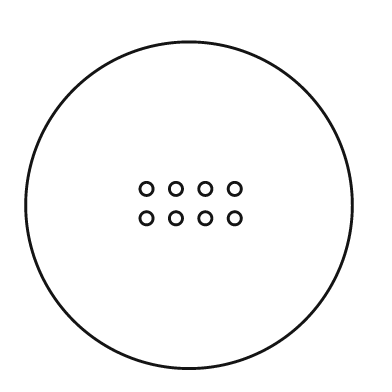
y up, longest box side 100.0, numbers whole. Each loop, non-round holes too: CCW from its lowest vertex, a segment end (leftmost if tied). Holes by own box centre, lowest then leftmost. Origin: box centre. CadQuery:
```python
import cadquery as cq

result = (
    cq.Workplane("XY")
    .moveTo(0.0, 0.0)
    .circle(50.0)
    .moveTo(-13.0, -4.0)
    .circle(2.0)
    .moveTo(-4.0, -4.0)
    .circle(2.0)
    .moveTo(5.0, -4.0)
    .circle(2.0)
    .moveTo(14.0, -4.0)
    .circle(2.0)
    .moveTo(-13.0, 5.0)
    .circle(2.0)
    .moveTo(-4.0, 5.0)
    .circle(2.0)
    .moveTo(5.0, 5.0)
    .circle(2.0)
    .moveTo(14.0, 5.0)
    .circle(2.0)
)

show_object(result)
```